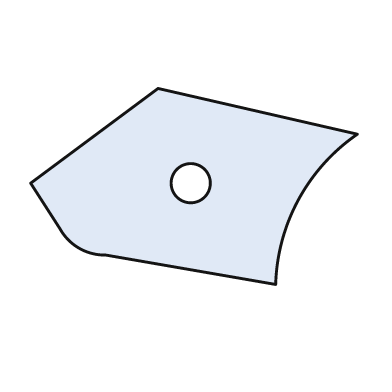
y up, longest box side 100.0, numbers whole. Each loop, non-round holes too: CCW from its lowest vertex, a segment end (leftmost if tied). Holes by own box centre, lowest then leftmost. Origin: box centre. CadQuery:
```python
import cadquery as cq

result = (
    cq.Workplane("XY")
    .moveTo(25.0, -30.0)
    .threePointArc((32.0, -4.0), (50.0, 16.0))
    .lineTo(-11.0, 30.0)
    .lineTo(-50.0, 1.0)
    .lineTo(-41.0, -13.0)
    .threePointArc((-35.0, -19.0), (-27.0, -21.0))
    .close()
    .moveTo(-1.0, 1.0)
    .circle(6.0)
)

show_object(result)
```